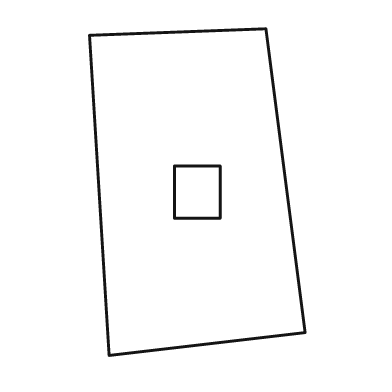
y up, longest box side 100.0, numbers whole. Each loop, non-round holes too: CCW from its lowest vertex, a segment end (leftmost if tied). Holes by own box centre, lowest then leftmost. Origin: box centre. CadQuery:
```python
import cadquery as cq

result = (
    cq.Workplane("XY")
    .moveTo(-27.0, -50.0)
    .lineTo(33.0, -43.0)
    .lineTo(21.0, 50.0)
    .lineTo(-33.0, 48.0)
    .close()
    .moveTo(-7.0, -8.0)
    .lineTo(7.0, -8.0)
    .lineTo(7.0, 8.0)
    .lineTo(-7.0, 8.0)
    .close()
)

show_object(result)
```